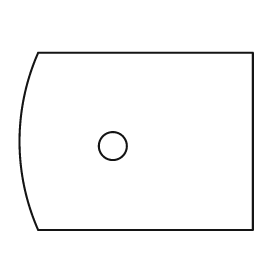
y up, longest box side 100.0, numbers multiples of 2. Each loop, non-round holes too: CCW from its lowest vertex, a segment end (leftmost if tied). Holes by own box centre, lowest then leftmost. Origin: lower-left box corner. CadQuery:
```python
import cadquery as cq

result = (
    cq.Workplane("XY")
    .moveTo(8.0, 0.0)
    .lineTo(100.0, 0.0)
    .lineTo(100.0, 76.0)
    .lineTo(8.0, 76.0)
    .threePointArc((0.0, 38.0), (8.0, 0.0))
    .close()
    .moveTo(40.0, 36.0)
    .circle(6.0)
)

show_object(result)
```